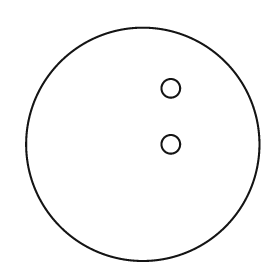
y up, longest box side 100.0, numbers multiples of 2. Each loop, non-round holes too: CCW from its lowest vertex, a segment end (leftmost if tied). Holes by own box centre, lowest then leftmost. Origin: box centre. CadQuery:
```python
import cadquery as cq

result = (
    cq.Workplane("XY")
    .moveTo(0.0, 0.0)
    .circle(50.0)
    .moveTo(12.0, 0.0)
    .circle(4.0)
    .moveTo(12.0, 24.0)
    .circle(4.0)
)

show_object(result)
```